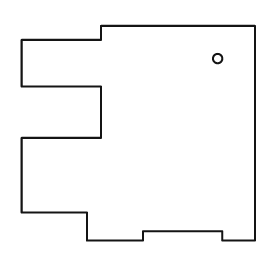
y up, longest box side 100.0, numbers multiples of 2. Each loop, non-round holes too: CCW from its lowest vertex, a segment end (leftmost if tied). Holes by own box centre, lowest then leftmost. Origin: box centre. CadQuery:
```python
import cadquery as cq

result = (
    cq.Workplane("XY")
    .moveTo(-22.0, -46.0)
    .lineTo(2.0, -46.0)
    .lineTo(2.0, -42.0)
    .lineTo(36.0, -42.0)
    .lineTo(36.0, -46.0)
    .lineTo(50.0, -46.0)
    .lineTo(50.0, 46.0)
    .lineTo(-16.0, 46.0)
    .lineTo(-16.0, 40.0)
    .lineTo(-50.0, 40.0)
    .lineTo(-50.0, 20.0)
    .lineTo(-16.0, 20.0)
    .lineTo(-16.0, -2.0)
    .lineTo(-50.0, -2.0)
    .lineTo(-50.0, -34.0)
    .lineTo(-22.0, -34.0)
    .close()
    .moveTo(34.0, 32.0)
    .circle(2.0)
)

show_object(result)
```